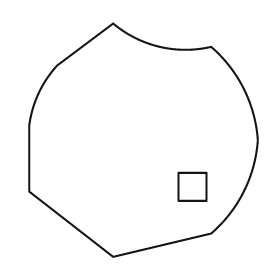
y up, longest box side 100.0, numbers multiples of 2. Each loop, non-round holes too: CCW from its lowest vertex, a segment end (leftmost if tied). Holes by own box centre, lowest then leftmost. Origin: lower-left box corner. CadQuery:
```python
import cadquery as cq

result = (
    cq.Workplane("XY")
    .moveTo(36.0, 0.0)
    .lineTo(78.0, 10.0)
    .threePointArc((92.0, 28.0), (98.0, 50.0))
    .threePointArc((92.0, 72.0), (78.0, 90.0))
    .threePointArc((56.0, 90.0), (36.0, 100.0))
    .lineTo(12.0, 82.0)
    .threePointArc((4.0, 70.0), (0.0, 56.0))
    .lineTo(0.0, 28.0)
    .close()
    .moveTo(64.0, 24.0)
    .lineTo(76.0, 24.0)
    .lineTo(76.0, 36.0)
    .lineTo(64.0, 36.0)
    .close()
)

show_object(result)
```